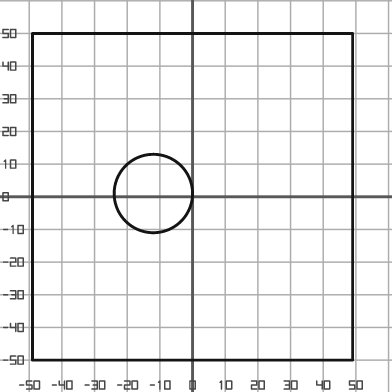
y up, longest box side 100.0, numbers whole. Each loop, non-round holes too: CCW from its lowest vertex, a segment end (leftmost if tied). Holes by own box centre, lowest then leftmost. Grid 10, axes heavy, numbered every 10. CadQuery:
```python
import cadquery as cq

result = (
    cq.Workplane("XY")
    .moveTo(-49.0, -50.0)
    .lineTo(49.0, -50.0)
    .lineTo(49.0, 50.0)
    .lineTo(-49.0, 50.0)
    .close()
    .moveTo(-12.0, 1.0)
    .circle(12.0)
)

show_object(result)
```